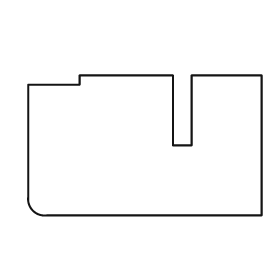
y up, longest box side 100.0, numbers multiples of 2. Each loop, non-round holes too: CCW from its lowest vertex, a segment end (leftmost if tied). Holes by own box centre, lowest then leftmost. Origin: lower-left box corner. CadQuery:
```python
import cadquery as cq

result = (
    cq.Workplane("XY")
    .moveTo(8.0, 0.0)
    .lineTo(100.0, 0.0)
    .lineTo(100.0, 60.0)
    .lineTo(70.0, 60.0)
    .lineTo(70.0, 30.0)
    .lineTo(62.0, 30.0)
    .lineTo(62.0, 60.0)
    .lineTo(22.0, 60.0)
    .lineTo(22.0, 56.0)
    .lineTo(0.0, 56.0)
    .lineTo(0.0, 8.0)
    .threePointArc((2.0, 2.0), (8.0, 0.0))
    .close()
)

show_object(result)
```